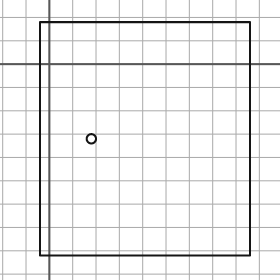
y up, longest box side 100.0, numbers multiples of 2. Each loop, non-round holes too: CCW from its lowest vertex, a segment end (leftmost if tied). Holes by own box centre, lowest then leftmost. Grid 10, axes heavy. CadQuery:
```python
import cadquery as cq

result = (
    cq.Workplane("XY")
    .moveTo(-4.0, -82.0)
    .lineTo(86.0, -82.0)
    .lineTo(86.0, 18.0)
    .lineTo(-4.0, 18.0)
    .close()
    .moveTo(18.0, -32.0)
    .circle(2.0)
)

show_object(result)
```